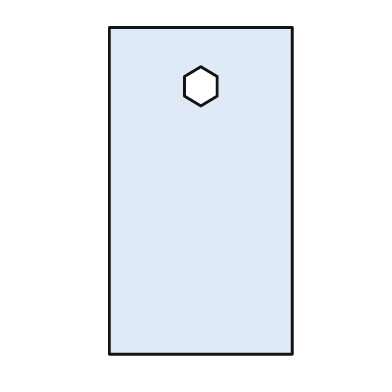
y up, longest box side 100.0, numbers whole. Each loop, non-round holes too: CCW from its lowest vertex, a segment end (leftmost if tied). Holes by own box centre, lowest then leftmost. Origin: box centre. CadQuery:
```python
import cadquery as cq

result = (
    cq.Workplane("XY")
    .moveTo(-28.0, -50.0)
    .lineTo(28.0, -50.0)
    .lineTo(28.0, 50.0)
    .lineTo(-28.0, 50.0)
    .close()
    .moveTo(0.0, 26.0)
    .lineTo(5.0, 29.0)
    .lineTo(5.0, 35.0)
    .lineTo(0.0, 38.0)
    .lineTo(-5.0, 35.0)
    .lineTo(-5.0, 29.0)
    .close()
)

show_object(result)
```